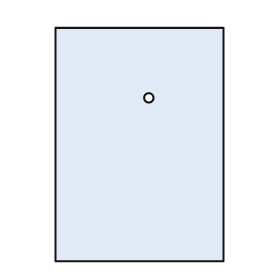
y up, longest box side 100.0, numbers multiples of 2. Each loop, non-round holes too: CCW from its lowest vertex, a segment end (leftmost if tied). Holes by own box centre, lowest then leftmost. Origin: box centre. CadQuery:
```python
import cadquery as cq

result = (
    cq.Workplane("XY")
    .moveTo(-36.0, -50.0)
    .lineTo(36.0, -50.0)
    .lineTo(36.0, 50.0)
    .lineTo(-36.0, 50.0)
    .close()
    .moveTo(4.0, 20.0)
    .circle(2.0)
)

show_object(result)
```